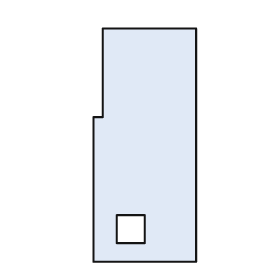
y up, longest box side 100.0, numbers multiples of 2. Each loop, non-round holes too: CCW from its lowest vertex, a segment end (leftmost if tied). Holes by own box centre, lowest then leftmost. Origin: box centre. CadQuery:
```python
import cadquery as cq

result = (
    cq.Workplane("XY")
    .moveTo(-22.0, -50.0)
    .lineTo(22.0, -50.0)
    .lineTo(22.0, 50.0)
    .lineTo(-18.0, 50.0)
    .lineTo(-18.0, 12.0)
    .lineTo(-22.0, 12.0)
    .close()
    .moveTo(-12.0, -42.0)
    .lineTo(0.0, -42.0)
    .lineTo(0.0, -30.0)
    .lineTo(-12.0, -30.0)
    .close()
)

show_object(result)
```